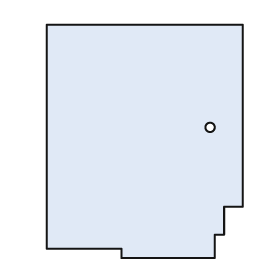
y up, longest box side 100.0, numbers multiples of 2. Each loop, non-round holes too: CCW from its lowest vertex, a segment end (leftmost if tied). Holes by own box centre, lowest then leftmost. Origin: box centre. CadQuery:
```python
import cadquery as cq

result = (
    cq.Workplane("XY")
    .moveTo(-10.0, -50.0)
    .lineTo(30.0, -50.0)
    .lineTo(30.0, -40.0)
    .lineTo(34.0, -40.0)
    .lineTo(34.0, -28.0)
    .lineTo(42.0, -28.0)
    .lineTo(42.0, 50.0)
    .lineTo(-42.0, 50.0)
    .lineTo(-42.0, -46.0)
    .lineTo(-10.0, -46.0)
    .close()
    .moveTo(28.0, 6.0)
    .circle(2.0)
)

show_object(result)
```